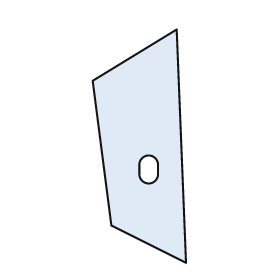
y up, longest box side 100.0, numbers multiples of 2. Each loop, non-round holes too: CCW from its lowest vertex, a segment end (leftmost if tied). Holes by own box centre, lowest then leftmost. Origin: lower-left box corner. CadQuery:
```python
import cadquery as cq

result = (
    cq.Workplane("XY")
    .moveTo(40.0, 0.0)
    .lineTo(36.0, 100.0)
    .lineTo(0.0, 78.0)
    .lineTo(8.0, 16.0)
    .close()
    .moveTo(20.0, 38.0)
    .threePointArc((24.0, 34.0), (28.0, 38.0))
    .lineTo(28.0, 42.0)
    .threePointArc((24.0, 46.0), (20.0, 42.0))
    .close()
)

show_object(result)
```